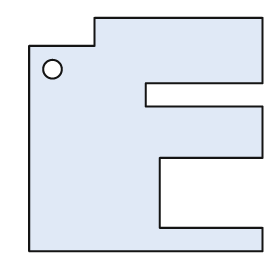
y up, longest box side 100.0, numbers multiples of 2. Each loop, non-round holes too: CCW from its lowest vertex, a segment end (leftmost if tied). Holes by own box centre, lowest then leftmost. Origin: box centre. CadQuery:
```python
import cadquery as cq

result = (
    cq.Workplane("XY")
    .moveTo(-50.0, -50.0)
    .lineTo(50.0, -50.0)
    .lineTo(50.0, -40.0)
    .lineTo(6.0, -40.0)
    .lineTo(6.0, -10.0)
    .lineTo(50.0, -10.0)
    .lineTo(50.0, 12.0)
    .lineTo(0.0, 12.0)
    .lineTo(0.0, 22.0)
    .lineTo(50.0, 22.0)
    .lineTo(50.0, 50.0)
    .lineTo(-22.0, 50.0)
    .lineTo(-22.0, 38.0)
    .lineTo(-50.0, 38.0)
    .close()
    .moveTo(-40.0, 28.0)
    .circle(4.0)
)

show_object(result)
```